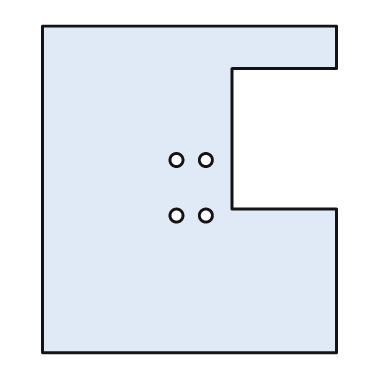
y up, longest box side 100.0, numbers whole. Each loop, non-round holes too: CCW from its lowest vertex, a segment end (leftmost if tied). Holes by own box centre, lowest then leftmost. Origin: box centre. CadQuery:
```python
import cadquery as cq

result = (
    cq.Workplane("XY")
    .moveTo(-45.0, -50.0)
    .lineTo(45.0, -50.0)
    .lineTo(45.0, -6.0)
    .lineTo(13.0, -6.0)
    .lineTo(13.0, 37.0)
    .lineTo(45.0, 37.0)
    .lineTo(45.0, 50.0)
    .lineTo(-45.0, 50.0)
    .close()
    .moveTo(-4.0, -8.0)
    .circle(2.0)
    .moveTo(5.0, -8.0)
    .circle(2.0)
    .moveTo(-4.0, 9.0)
    .circle(2.0)
    .moveTo(5.0, 9.0)
    .circle(2.0)
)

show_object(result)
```